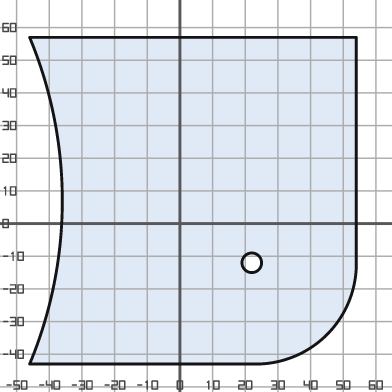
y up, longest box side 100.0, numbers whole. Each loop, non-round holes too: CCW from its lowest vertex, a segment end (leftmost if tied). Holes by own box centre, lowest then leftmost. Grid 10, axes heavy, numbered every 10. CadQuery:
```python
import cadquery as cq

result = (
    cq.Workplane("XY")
    .moveTo(-46.0, -43.0)
    .lineTo(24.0, -43.0)
    .threePointArc((45.0, -34.0), (54.0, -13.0))
    .lineTo(54.0, 57.0)
    .lineTo(-46.0, 57.0)
    .threePointArc((-36.0, 7.0), (-46.0, -43.0))
    .close()
    .moveTo(22.0, -12.0)
    .circle(3.0)
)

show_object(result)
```